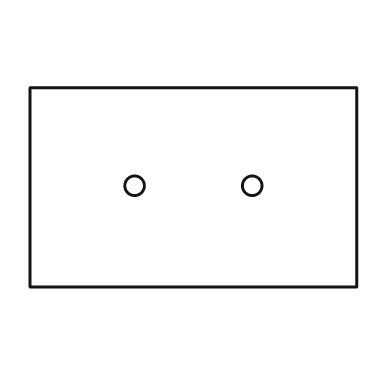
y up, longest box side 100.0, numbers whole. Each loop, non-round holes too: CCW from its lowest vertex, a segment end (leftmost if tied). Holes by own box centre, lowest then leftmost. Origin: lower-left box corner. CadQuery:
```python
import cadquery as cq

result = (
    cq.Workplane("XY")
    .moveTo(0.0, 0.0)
    .lineTo(100.0, 0.0)
    .lineTo(100.0, 61.0)
    .lineTo(0.0, 61.0)
    .close()
    .moveTo(32.0, 31.0)
    .circle(3.0)
    .moveTo(68.0, 31.0)
    .circle(3.0)
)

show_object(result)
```